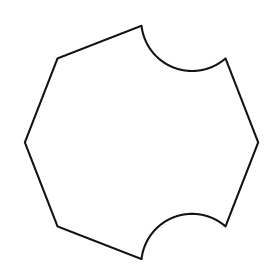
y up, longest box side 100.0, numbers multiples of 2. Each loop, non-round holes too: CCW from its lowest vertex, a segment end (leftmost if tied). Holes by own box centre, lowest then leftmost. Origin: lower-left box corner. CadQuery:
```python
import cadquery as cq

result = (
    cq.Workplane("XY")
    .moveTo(50.0, 0.0)
    .threePointArc((64.0, 18.0), (86.0, 14.0))
    .lineTo(100.0, 50.0)
    .lineTo(86.0, 86.0)
    .threePointArc((64.0, 82.0), (50.0, 100.0))
    .lineTo(14.0, 86.0)
    .lineTo(0.0, 50.0)
    .lineTo(14.0, 14.0)
    .close()
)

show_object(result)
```